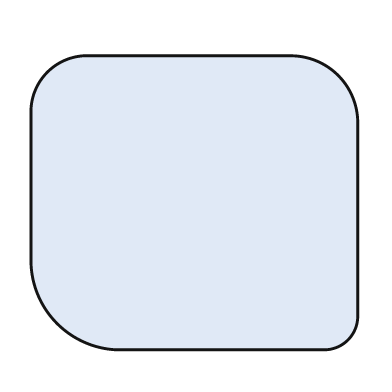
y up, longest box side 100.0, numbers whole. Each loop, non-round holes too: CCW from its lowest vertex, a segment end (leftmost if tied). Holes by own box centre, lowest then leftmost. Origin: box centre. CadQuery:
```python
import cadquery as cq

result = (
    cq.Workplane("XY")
    .moveTo(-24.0, -45.0)
    .lineTo(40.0, -45.0)
    .threePointArc((47.0, -42.0), (50.0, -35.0))
    .lineTo(50.0, 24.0)
    .threePointArc((44.0, 39.0), (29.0, 45.0))
    .lineTo(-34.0, 45.0)
    .threePointArc((-45.0, 40.0), (-50.0, 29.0))
    .lineTo(-50.0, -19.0)
    .threePointArc((-42.0, -37.0), (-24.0, -45.0))
    .close()
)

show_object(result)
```